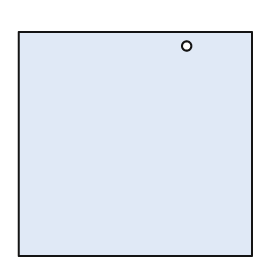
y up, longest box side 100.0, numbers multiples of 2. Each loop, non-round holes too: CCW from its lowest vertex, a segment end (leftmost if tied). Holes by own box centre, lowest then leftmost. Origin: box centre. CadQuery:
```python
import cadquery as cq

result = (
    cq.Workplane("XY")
    .moveTo(-50.0, -48.0)
    .lineTo(50.0, -48.0)
    .lineTo(50.0, 48.0)
    .lineTo(-50.0, 48.0)
    .close()
    .moveTo(22.0, 42.0)
    .circle(2.0)
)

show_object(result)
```